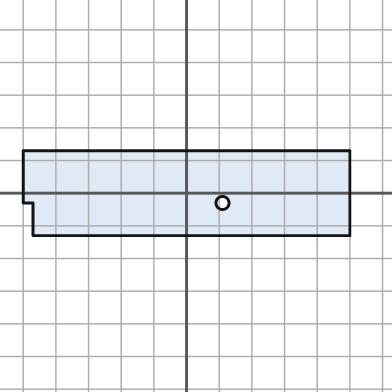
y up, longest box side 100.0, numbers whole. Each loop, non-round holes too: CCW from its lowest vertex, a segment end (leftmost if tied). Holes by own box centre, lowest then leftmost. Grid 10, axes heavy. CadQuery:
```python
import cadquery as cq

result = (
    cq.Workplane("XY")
    .moveTo(-47.0, -13.0)
    .lineTo(50.0, -13.0)
    .lineTo(50.0, 13.0)
    .lineTo(-50.0, 13.0)
    .lineTo(-50.0, -3.0)
    .lineTo(-47.0, -3.0)
    .close()
    .moveTo(11.0, -3.0)
    .circle(2.0)
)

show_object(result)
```